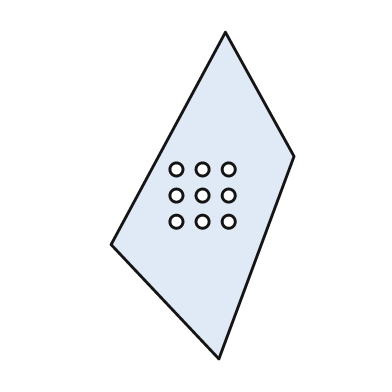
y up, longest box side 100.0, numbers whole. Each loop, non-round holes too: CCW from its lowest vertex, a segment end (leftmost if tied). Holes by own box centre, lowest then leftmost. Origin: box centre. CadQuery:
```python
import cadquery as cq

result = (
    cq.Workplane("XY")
    .moveTo(5.0, -50.0)
    .lineTo(28.0, 12.0)
    .lineTo(7.0, 50.0)
    .lineTo(-28.0, -15.0)
    .close()
    .moveTo(-8.0, -8.0)
    .circle(2.0)
    .moveTo(0.0, -8.0)
    .circle(2.0)
    .moveTo(8.0, -8.0)
    .circle(2.0)
    .moveTo(-8.0, 0.0)
    .circle(2.0)
    .moveTo(0.0, 0.0)
    .circle(2.0)
    .moveTo(8.0, 0.0)
    .circle(2.0)
    .moveTo(-8.0, 8.0)
    .circle(2.0)
    .moveTo(0.0, 8.0)
    .circle(2.0)
    .moveTo(8.0, 8.0)
    .circle(2.0)
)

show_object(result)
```